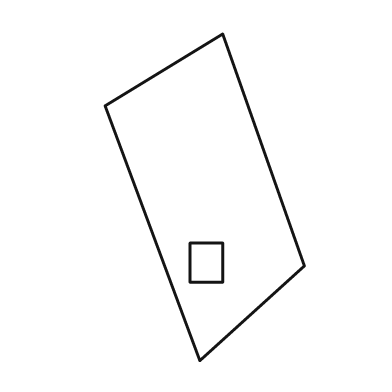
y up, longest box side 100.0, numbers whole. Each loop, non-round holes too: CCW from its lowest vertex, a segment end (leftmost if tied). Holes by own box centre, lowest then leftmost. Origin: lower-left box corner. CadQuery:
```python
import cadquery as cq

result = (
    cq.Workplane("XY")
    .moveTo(29.0, 0.0)
    .lineTo(61.0, 29.0)
    .lineTo(36.0, 100.0)
    .lineTo(0.0, 78.0)
    .close()
    .moveTo(26.0, 24.0)
    .lineTo(36.0, 24.0)
    .lineTo(36.0, 36.0)
    .lineTo(26.0, 36.0)
    .close()
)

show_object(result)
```